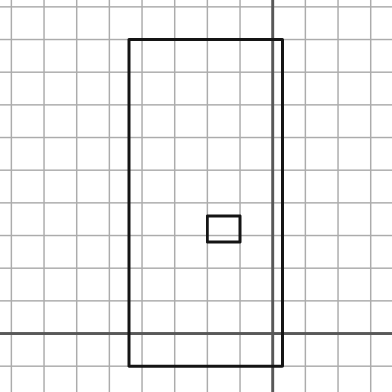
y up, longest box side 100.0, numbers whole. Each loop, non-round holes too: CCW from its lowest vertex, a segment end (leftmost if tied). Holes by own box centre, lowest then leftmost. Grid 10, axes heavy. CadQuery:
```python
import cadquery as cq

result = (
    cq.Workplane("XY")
    .moveTo(-44.0, -10.0)
    .lineTo(3.0, -10.0)
    .lineTo(3.0, 90.0)
    .lineTo(-44.0, 90.0)
    .close()
    .moveTo(-20.0, 28.0)
    .lineTo(-10.0, 28.0)
    .lineTo(-10.0, 36.0)
    .lineTo(-20.0, 36.0)
    .close()
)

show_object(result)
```